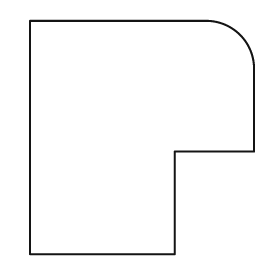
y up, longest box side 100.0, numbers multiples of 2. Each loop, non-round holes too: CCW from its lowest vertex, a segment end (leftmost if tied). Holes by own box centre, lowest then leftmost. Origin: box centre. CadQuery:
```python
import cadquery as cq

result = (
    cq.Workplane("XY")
    .moveTo(-48.0, -50.0)
    .lineTo(14.0, -50.0)
    .lineTo(14.0, -6.0)
    .lineTo(48.0, -6.0)
    .lineTo(48.0, 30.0)
    .threePointArc((42.0, 44.0), (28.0, 50.0))
    .lineTo(-48.0, 50.0)
    .close()
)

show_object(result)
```